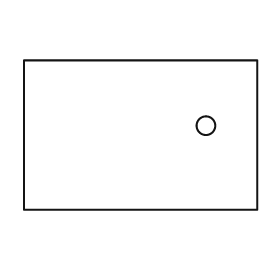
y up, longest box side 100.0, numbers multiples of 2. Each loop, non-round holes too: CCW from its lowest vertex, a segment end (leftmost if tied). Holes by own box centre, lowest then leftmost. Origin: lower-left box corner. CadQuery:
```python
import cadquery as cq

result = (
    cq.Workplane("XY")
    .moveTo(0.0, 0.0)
    .lineTo(100.0, 0.0)
    .lineTo(100.0, 64.0)
    .lineTo(0.0, 64.0)
    .close()
    .moveTo(78.0, 36.0)
    .circle(4.0)
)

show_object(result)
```